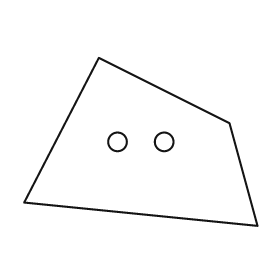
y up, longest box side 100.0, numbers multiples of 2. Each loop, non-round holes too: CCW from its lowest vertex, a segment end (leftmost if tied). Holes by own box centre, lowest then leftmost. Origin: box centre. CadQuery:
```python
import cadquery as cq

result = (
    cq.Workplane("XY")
    .moveTo(50.0, -36.0)
    .lineTo(38.0, 8.0)
    .lineTo(-18.0, 36.0)
    .lineTo(-50.0, -26.0)
    .close()
    .moveTo(-10.0, 0.0)
    .circle(4.0)
    .moveTo(10.0, 0.0)
    .circle(4.0)
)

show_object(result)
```